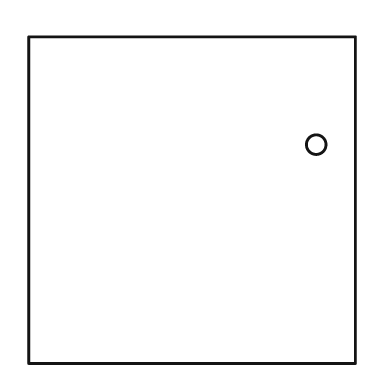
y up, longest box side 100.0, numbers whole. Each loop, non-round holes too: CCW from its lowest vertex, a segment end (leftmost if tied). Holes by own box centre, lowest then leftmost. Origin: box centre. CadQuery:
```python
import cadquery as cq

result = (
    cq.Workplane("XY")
    .moveTo(-50.0, -50.0)
    .lineTo(50.0, -50.0)
    .lineTo(50.0, 50.0)
    .lineTo(-50.0, 50.0)
    .close()
    .moveTo(38.0, 17.0)
    .circle(3.0)
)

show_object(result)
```